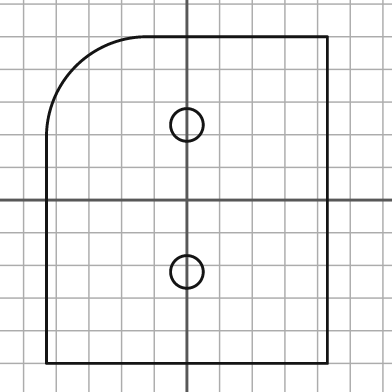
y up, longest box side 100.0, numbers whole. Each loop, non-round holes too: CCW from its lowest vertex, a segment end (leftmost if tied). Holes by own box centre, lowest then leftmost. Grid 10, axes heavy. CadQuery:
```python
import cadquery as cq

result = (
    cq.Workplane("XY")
    .moveTo(-43.0, -50.0)
    .lineTo(43.0, -50.0)
    .lineTo(43.0, 50.0)
    .lineTo(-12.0, 50.0)
    .threePointArc((-34.0, 41.0), (-43.0, 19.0))
    .close()
    .moveTo(0.0, -22.0)
    .circle(5.0)
    .moveTo(0.0, 23.0)
    .circle(5.0)
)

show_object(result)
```